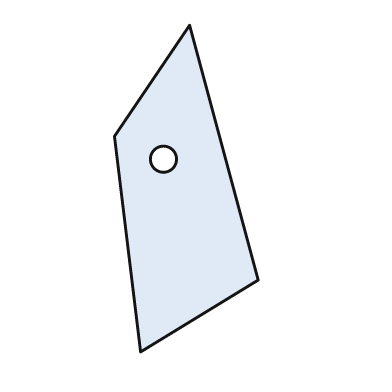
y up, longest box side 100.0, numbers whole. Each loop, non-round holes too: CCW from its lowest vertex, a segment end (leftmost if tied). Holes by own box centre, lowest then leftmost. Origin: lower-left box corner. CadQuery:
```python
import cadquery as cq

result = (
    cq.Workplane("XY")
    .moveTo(8.0, 0.0)
    .lineTo(44.0, 22.0)
    .lineTo(23.0, 100.0)
    .lineTo(0.0, 66.0)
    .close()
    .moveTo(15.0, 59.0)
    .circle(4.0)
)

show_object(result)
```